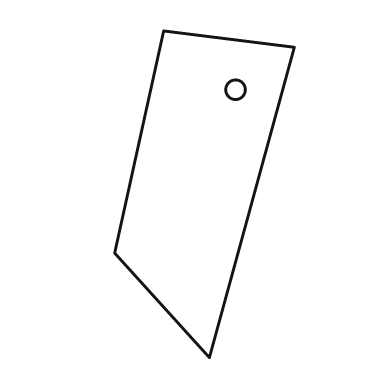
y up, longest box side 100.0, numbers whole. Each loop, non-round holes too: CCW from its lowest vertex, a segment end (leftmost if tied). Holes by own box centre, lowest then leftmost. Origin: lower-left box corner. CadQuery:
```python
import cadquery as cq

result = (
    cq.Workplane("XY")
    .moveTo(29.0, 0.0)
    .lineTo(55.0, 95.0)
    .lineTo(15.0, 100.0)
    .lineTo(0.0, 32.0)
    .close()
    .moveTo(37.0, 82.0)
    .circle(3.0)
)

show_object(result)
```